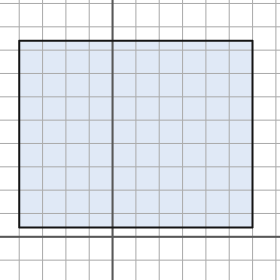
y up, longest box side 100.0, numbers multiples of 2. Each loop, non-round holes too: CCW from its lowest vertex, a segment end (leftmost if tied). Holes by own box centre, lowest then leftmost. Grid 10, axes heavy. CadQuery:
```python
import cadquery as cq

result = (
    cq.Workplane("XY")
    .moveTo(-40.0, 4.0)
    .lineTo(60.0, 4.0)
    .lineTo(60.0, 84.0)
    .lineTo(-40.0, 84.0)
    .close()
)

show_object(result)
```